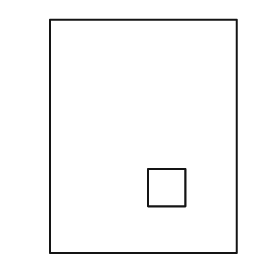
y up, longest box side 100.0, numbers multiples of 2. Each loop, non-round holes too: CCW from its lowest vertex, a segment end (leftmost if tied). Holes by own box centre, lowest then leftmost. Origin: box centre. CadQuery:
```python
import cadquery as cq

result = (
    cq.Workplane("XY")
    .moveTo(-40.0, -50.0)
    .lineTo(40.0, -50.0)
    .lineTo(40.0, 50.0)
    .lineTo(-40.0, 50.0)
    .close()
    .moveTo(2.0, -30.0)
    .lineTo(18.0, -30.0)
    .lineTo(18.0, -14.0)
    .lineTo(2.0, -14.0)
    .close()
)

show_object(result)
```